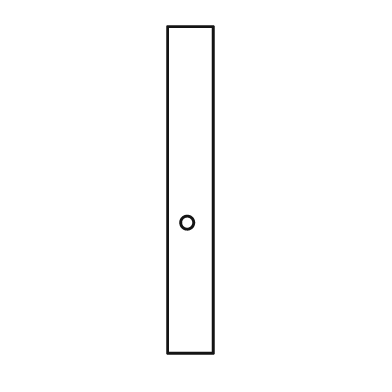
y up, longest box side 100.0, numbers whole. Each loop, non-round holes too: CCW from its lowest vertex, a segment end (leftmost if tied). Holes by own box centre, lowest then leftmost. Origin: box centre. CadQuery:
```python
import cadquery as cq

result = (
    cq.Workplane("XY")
    .moveTo(-7.0, -50.0)
    .lineTo(7.0, -50.0)
    .lineTo(7.0, 50.0)
    .lineTo(-7.0, 50.0)
    .close()
    .moveTo(-1.0, -10.0)
    .circle(2.0)
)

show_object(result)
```